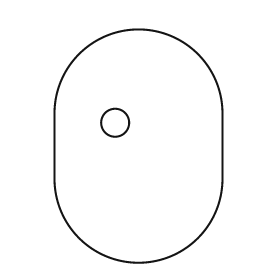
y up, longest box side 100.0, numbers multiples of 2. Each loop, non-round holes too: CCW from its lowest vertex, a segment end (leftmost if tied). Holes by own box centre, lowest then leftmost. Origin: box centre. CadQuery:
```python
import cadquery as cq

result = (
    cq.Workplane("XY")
    .moveTo(-36.0, -14.0)
    .threePointArc((0.0, -50.0), (36.0, -14.0))
    .lineTo(36.0, 14.0)
    .threePointArc((0.0, 50.0), (-36.0, 14.0))
    .close()
    .moveTo(-10.0, 10.0)
    .circle(6.0)
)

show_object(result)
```